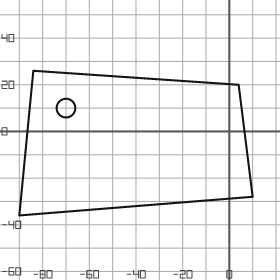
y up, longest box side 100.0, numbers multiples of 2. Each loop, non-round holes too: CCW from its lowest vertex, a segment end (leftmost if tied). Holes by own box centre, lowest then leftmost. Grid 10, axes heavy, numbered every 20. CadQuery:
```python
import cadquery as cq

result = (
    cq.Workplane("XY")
    .moveTo(-90.0, -36.0)
    .lineTo(10.0, -28.0)
    .lineTo(4.0, 20.0)
    .lineTo(-84.0, 26.0)
    .close()
    .moveTo(-70.0, 10.0)
    .circle(4.0)
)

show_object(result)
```